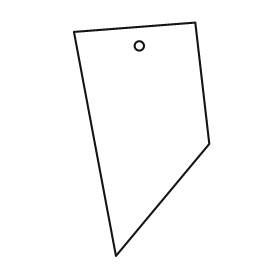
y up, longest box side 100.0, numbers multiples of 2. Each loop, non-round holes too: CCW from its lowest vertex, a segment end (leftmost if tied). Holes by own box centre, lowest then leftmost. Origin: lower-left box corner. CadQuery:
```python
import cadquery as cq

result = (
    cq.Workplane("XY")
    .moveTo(18.0, 0.0)
    .lineTo(58.0, 48.0)
    .lineTo(52.0, 100.0)
    .lineTo(0.0, 96.0)
    .close()
    .moveTo(28.0, 90.0)
    .circle(2.0)
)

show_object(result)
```